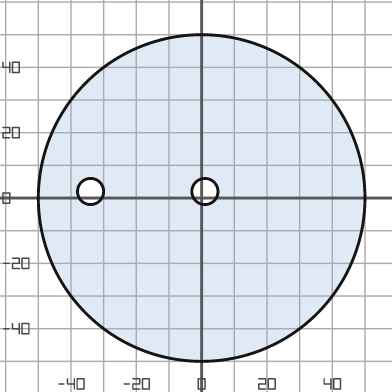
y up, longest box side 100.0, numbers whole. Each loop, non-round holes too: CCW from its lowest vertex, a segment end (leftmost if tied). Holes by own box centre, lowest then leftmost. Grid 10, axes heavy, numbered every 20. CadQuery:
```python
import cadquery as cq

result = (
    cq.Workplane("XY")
    .moveTo(0.0, 0.0)
    .circle(50.0)
    .moveTo(-34.0, 2.0)
    .circle(4.0)
    .moveTo(1.0, 2.0)
    .circle(4.0)
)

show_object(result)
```